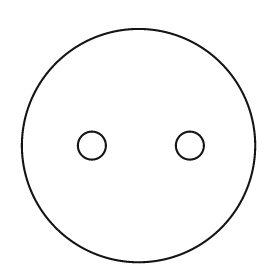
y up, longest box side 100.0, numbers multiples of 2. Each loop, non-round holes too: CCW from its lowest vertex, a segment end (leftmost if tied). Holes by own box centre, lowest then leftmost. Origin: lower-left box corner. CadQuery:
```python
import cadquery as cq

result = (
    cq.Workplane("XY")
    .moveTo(50.0, 50.0)
    .circle(50.0)
    .moveTo(30.0, 50.0)
    .circle(6.0)
    .moveTo(72.0, 50.0)
    .circle(6.0)
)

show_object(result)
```